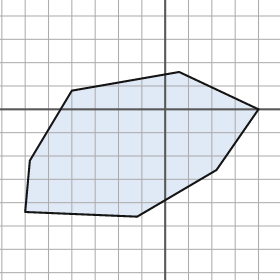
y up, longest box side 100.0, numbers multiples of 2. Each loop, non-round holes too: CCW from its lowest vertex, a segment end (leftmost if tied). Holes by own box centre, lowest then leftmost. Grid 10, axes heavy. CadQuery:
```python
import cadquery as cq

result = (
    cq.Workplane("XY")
    .moveTo(-12.0, -46.0)
    .lineTo(22.0, -26.0)
    .lineTo(40.0, 0.0)
    .lineTo(6.0, 16.0)
    .lineTo(-40.0, 8.0)
    .lineTo(-58.0, -22.0)
    .lineTo(-60.0, -44.0)
    .close()
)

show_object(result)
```